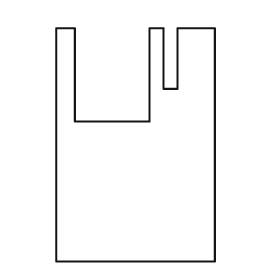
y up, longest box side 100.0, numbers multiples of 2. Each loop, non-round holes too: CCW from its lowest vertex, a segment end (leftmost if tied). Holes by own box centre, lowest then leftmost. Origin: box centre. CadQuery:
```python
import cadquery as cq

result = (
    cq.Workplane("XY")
    .moveTo(-34.0, -50.0)
    .lineTo(34.0, -50.0)
    .lineTo(34.0, 50.0)
    .lineTo(18.0, 50.0)
    .lineTo(18.0, 24.0)
    .lineTo(12.0, 24.0)
    .lineTo(12.0, 50.0)
    .lineTo(6.0, 50.0)
    .lineTo(6.0, 10.0)
    .lineTo(-26.0, 10.0)
    .lineTo(-26.0, 50.0)
    .lineTo(-34.0, 50.0)
    .close()
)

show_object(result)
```